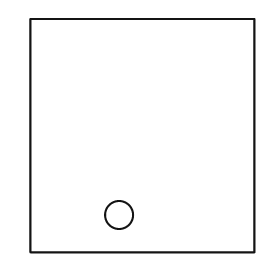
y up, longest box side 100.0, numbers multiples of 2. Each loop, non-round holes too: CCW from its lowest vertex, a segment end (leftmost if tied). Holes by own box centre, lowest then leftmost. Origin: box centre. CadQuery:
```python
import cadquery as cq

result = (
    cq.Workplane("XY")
    .moveTo(-48.0, -50.0)
    .lineTo(48.0, -50.0)
    .lineTo(48.0, 50.0)
    .lineTo(-48.0, 50.0)
    .close()
    .moveTo(-10.0, -34.0)
    .circle(6.0)
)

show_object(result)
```